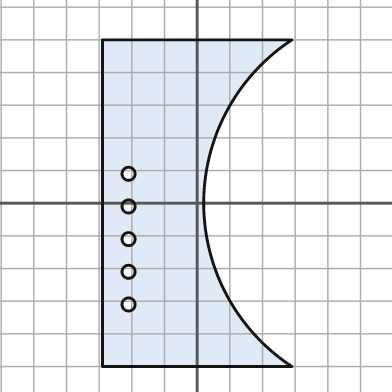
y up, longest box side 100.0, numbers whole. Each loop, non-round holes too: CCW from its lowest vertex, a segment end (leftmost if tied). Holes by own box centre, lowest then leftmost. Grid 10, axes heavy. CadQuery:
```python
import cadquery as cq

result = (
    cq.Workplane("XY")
    .moveTo(-29.0, -50.0)
    .lineTo(29.0, -50.0)
    .threePointArc((2.0, 0.0), (29.0, 50.0))
    .lineTo(-29.0, 50.0)
    .close()
    .moveTo(-21.0, -31.0)
    .circle(2.0)
    .moveTo(-21.0, -21.0)
    .circle(2.0)
    .moveTo(-21.0, -11.0)
    .circle(2.0)
    .moveTo(-21.0, -1.0)
    .circle(2.0)
    .moveTo(-21.0, 9.0)
    .circle(2.0)
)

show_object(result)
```